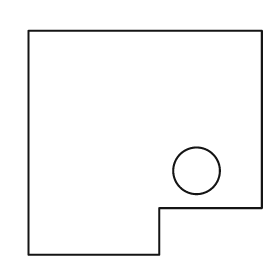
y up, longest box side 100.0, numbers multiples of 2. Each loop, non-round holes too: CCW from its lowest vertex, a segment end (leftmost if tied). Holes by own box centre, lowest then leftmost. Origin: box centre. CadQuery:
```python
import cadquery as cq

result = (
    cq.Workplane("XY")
    .moveTo(-50.0, -48.0)
    .lineTo(6.0, -48.0)
    .lineTo(6.0, -28.0)
    .lineTo(50.0, -28.0)
    .lineTo(50.0, 48.0)
    .lineTo(-50.0, 48.0)
    .close()
    .moveTo(22.0, -12.0)
    .circle(10.0)
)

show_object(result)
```